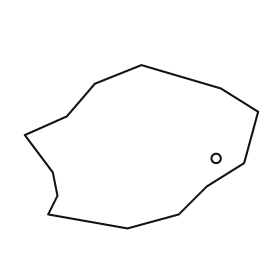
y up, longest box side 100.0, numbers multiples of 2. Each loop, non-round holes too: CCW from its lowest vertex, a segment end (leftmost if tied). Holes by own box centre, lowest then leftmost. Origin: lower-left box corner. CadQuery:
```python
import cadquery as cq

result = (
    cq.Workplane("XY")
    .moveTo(44.0, 0.0)
    .lineTo(66.0, 6.0)
    .lineTo(78.0, 18.0)
    .lineTo(94.0, 28.0)
    .lineTo(100.0, 50.0)
    .lineTo(84.0, 60.0)
    .lineTo(50.0, 70.0)
    .lineTo(30.0, 62.0)
    .lineTo(18.0, 48.0)
    .lineTo(0.0, 40.0)
    .lineTo(12.0, 24.0)
    .lineTo(14.0, 14.0)
    .lineTo(10.0, 6.0)
    .close()
    .moveTo(82.0, 30.0)
    .circle(2.0)
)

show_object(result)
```